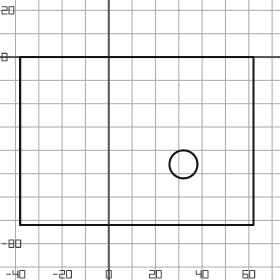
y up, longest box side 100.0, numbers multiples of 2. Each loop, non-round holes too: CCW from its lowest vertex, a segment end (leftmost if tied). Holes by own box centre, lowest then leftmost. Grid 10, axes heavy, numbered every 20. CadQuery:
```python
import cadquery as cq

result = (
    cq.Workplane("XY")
    .moveTo(-38.0, -72.0)
    .lineTo(62.0, -72.0)
    .lineTo(62.0, 0.0)
    .lineTo(-38.0, 0.0)
    .close()
    .moveTo(32.0, -46.0)
    .circle(6.0)
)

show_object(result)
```